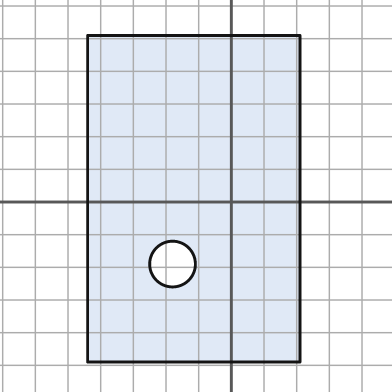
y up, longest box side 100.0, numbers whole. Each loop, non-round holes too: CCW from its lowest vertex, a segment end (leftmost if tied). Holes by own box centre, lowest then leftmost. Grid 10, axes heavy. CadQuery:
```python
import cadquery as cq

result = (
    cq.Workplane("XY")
    .moveTo(-44.0, -49.0)
    .lineTo(21.0, -49.0)
    .lineTo(21.0, 51.0)
    .lineTo(-44.0, 51.0)
    .close()
    .moveTo(-18.0, -19.0)
    .circle(7.0)
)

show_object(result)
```